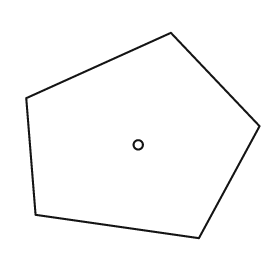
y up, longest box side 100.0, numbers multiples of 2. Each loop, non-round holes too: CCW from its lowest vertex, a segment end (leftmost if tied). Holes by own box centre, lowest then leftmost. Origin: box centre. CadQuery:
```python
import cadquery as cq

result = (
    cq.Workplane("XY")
    .moveTo(24.0, -44.0)
    .lineTo(50.0, 4.0)
    .lineTo(12.0, 44.0)
    .lineTo(-50.0, 16.0)
    .lineTo(-46.0, -34.0)
    .close()
    .moveTo(-2.0, -4.0)
    .circle(2.0)
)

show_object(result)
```